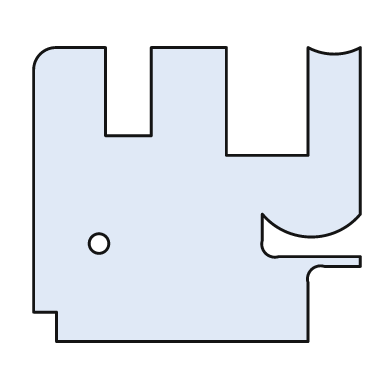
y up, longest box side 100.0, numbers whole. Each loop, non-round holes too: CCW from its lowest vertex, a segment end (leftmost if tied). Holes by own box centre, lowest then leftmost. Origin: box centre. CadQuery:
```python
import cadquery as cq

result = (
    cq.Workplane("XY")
    .moveTo(-43.0, -45.0)
    .lineTo(34.0, -45.0)
    .lineTo(34.0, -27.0)
    .threePointArc((35.0, -23.0), (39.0, -22.0))
    .lineTo(50.0, -22.0)
    .lineTo(50.0, -19.0)
    .lineTo(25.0, -19.0)
    .threePointArc((21.0, -18.0), (20.0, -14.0))
    .lineTo(20.0, -6.0)
    .threePointArc((35.0, -13.0), (50.0, -6.0))
    .lineTo(50.0, 45.0)
    .threePointArc((42.0, 43.0), (34.0, 45.0))
    .lineTo(34.0, 12.0)
    .lineTo(9.0, 12.0)
    .lineTo(9.0, 45.0)
    .lineTo(-14.0, 45.0)
    .lineTo(-14.0, 18.0)
    .lineTo(-28.0, 18.0)
    .lineTo(-28.0, 45.0)
    .lineTo(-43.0, 45.0)
    .threePointArc((-48.0, 43.0), (-50.0, 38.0))
    .lineTo(-50.0, -36.0)
    .lineTo(-43.0, -36.0)
    .close()
    .moveTo(-30.0, -15.0)
    .circle(3.0)
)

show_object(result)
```